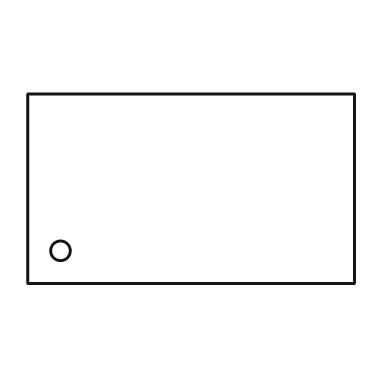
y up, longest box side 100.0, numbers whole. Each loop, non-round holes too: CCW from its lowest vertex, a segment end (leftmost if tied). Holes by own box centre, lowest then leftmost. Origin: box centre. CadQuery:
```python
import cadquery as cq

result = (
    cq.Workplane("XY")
    .moveTo(-50.0, -29.0)
    .lineTo(50.0, -29.0)
    .lineTo(50.0, 29.0)
    .lineTo(-50.0, 29.0)
    .close()
    .moveTo(-40.0, -19.0)
    .circle(3.0)
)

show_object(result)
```